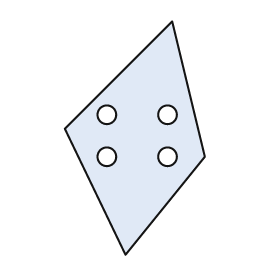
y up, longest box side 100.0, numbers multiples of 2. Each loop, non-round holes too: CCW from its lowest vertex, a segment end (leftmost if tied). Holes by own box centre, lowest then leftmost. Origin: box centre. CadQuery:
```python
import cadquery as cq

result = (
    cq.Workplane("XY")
    .moveTo(-4.0, -50.0)
    .lineTo(30.0, -8.0)
    .lineTo(16.0, 50.0)
    .lineTo(-30.0, 4.0)
    .close()
    .moveTo(-12.0, -8.0)
    .circle(4.0)
    .moveTo(14.0, -8.0)
    .circle(4.0)
    .moveTo(-12.0, 10.0)
    .circle(4.0)
    .moveTo(14.0, 10.0)
    .circle(4.0)
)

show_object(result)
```